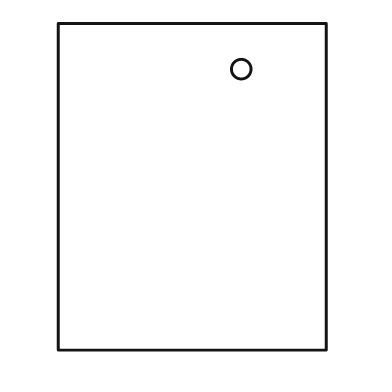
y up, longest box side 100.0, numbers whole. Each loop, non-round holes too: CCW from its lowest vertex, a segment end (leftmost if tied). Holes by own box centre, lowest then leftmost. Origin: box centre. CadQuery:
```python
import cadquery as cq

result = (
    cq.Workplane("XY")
    .moveTo(-41.0, -50.0)
    .lineTo(41.0, -50.0)
    .lineTo(41.0, 50.0)
    .lineTo(-41.0, 50.0)
    .close()
    .moveTo(15.0, 36.0)
    .circle(3.0)
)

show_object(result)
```